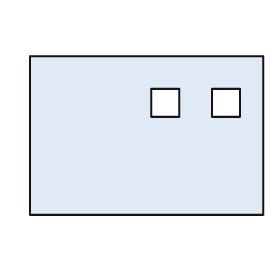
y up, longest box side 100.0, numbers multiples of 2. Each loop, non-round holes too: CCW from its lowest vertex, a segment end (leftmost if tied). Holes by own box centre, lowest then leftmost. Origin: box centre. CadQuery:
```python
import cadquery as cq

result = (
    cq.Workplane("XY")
    .moveTo(-50.0, -34.0)
    .lineTo(50.0, -34.0)
    .lineTo(50.0, 34.0)
    .lineTo(-50.0, 34.0)
    .close()
    .moveTo(2.0, 8.0)
    .lineTo(14.0, 8.0)
    .lineTo(14.0, 20.0)
    .lineTo(2.0, 20.0)
    .close()
    .moveTo(28.0, 8.0)
    .lineTo(40.0, 8.0)
    .lineTo(40.0, 20.0)
    .lineTo(28.0, 20.0)
    .close()
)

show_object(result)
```